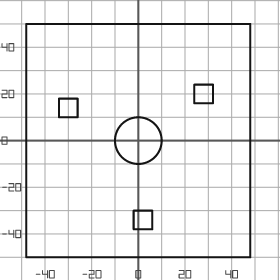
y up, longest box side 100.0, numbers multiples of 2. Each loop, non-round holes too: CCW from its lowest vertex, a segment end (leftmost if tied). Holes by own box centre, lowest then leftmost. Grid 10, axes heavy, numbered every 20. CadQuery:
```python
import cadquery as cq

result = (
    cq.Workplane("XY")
    .moveTo(-48.0, -50.0)
    .lineTo(48.0, -50.0)
    .lineTo(48.0, 50.0)
    .lineTo(-48.0, 50.0)
    .close()
    .moveTo(-2.0, -38.0)
    .lineTo(6.0, -38.0)
    .lineTo(6.0, -30.0)
    .lineTo(-2.0, -30.0)
    .close()
    .moveTo(0.0, 0.0)
    .circle(10.0)
    .moveTo(-34.0, 10.0)
    .lineTo(-26.0, 10.0)
    .lineTo(-26.0, 18.0)
    .lineTo(-34.0, 18.0)
    .close()
    .moveTo(24.0, 16.0)
    .lineTo(32.0, 16.0)
    .lineTo(32.0, 24.0)
    .lineTo(24.0, 24.0)
    .close()
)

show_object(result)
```